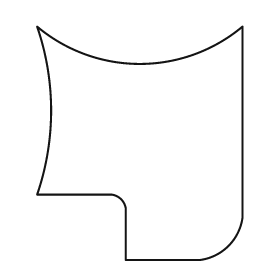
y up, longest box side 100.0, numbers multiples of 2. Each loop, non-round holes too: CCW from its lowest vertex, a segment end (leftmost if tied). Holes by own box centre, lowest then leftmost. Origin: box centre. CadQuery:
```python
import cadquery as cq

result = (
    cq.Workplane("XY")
    .moveTo(-6.0, -50.0)
    .lineTo(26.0, -50.0)
    .threePointArc((38.0, -44.0), (44.0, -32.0))
    .lineTo(44.0, 50.0)
    .threePointArc((0.0, 34.0), (-44.0, 50.0))
    .threePointArc((-38.0, 14.0), (-44.0, -22.0))
    .lineTo(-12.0, -22.0)
    .threePointArc((-8.0, -24.0), (-6.0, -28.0))
    .close()
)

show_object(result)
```